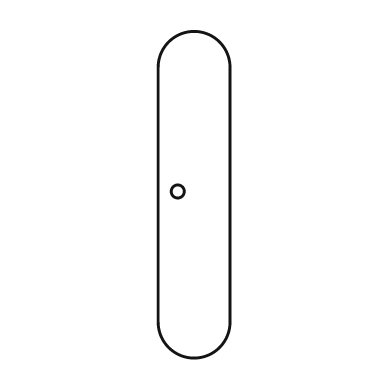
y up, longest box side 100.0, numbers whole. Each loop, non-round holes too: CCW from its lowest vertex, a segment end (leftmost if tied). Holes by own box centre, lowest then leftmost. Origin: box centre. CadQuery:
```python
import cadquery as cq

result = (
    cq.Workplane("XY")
    .moveTo(-11.0, -39.0)
    .threePointArc((0.0, -50.0), (11.0, -39.0))
    .lineTo(11.0, 39.0)
    .threePointArc((0.0, 50.0), (-11.0, 39.0))
    .close()
    .moveTo(-5.0, 1.0)
    .circle(2.0)
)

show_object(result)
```